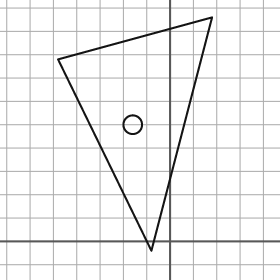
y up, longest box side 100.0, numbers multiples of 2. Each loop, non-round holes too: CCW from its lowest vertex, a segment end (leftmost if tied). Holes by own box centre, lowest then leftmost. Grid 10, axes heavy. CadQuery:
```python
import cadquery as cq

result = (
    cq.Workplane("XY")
    .moveTo(-8.0, -4.0)
    .lineTo(18.0, 96.0)
    .lineTo(-48.0, 78.0)
    .close()
    .moveTo(-16.0, 50.0)
    .circle(4.0)
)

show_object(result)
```